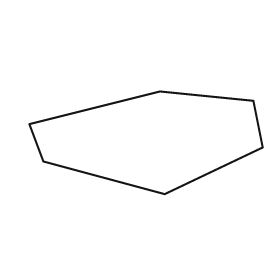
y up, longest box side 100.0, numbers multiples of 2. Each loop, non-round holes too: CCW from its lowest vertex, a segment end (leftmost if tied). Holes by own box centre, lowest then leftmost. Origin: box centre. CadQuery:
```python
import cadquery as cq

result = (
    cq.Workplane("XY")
    .moveTo(8.0, -22.0)
    .lineTo(50.0, -2.0)
    .lineTo(46.0, 18.0)
    .lineTo(6.0, 22.0)
    .lineTo(-50.0, 8.0)
    .lineTo(-44.0, -8.0)
    .close()
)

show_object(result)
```